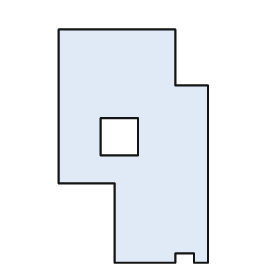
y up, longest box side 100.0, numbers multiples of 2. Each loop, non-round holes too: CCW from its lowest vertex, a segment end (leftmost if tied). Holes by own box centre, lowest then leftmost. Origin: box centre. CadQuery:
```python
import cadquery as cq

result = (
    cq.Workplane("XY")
    .moveTo(-8.0, -50.0)
    .lineTo(18.0, -50.0)
    .lineTo(18.0, -46.0)
    .lineTo(26.0, -46.0)
    .lineTo(26.0, -50.0)
    .lineTo(32.0, -50.0)
    .lineTo(32.0, 26.0)
    .lineTo(18.0, 26.0)
    .lineTo(18.0, 50.0)
    .lineTo(-32.0, 50.0)
    .lineTo(-32.0, -16.0)
    .lineTo(-8.0, -16.0)
    .close()
    .moveTo(-14.0, -4.0)
    .lineTo(2.0, -4.0)
    .lineTo(2.0, 12.0)
    .lineTo(-14.0, 12.0)
    .close()
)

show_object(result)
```